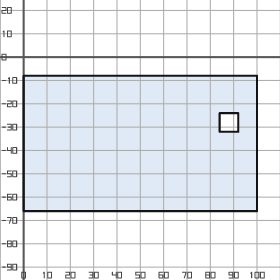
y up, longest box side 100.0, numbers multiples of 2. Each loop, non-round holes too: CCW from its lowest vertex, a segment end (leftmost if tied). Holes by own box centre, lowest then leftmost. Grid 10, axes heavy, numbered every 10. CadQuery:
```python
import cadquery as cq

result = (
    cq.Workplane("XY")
    .moveTo(0.0, -66.0)
    .lineTo(100.0, -66.0)
    .lineTo(100.0, -8.0)
    .lineTo(0.0, -8.0)
    .close()
    .moveTo(84.0, -32.0)
    .lineTo(92.0, -32.0)
    .lineTo(92.0, -24.0)
    .lineTo(84.0, -24.0)
    .close()
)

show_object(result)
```